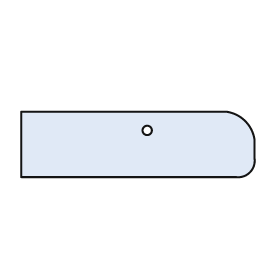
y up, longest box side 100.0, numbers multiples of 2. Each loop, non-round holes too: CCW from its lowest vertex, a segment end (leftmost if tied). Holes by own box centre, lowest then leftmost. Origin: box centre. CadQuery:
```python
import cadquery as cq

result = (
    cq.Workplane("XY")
    .moveTo(-50.0, -14.0)
    .lineTo(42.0, -14.0)
    .threePointArc((48.0, -12.0), (50.0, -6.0))
    .lineTo(50.0, 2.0)
    .threePointArc((46.0, 10.0), (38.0, 14.0))
    .lineTo(-50.0, 14.0)
    .close()
    .moveTo(4.0, 6.0)
    .circle(2.0)
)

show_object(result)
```